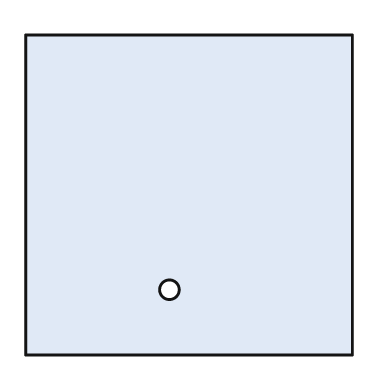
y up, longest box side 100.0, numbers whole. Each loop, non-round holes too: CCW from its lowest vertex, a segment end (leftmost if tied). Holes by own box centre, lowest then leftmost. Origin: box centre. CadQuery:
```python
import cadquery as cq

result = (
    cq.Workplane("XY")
    .moveTo(-50.0, -49.0)
    .lineTo(50.0, -49.0)
    .lineTo(50.0, 49.0)
    .lineTo(-50.0, 49.0)
    .close()
    .moveTo(-6.0, -29.0)
    .circle(3.0)
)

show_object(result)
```